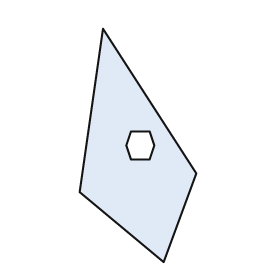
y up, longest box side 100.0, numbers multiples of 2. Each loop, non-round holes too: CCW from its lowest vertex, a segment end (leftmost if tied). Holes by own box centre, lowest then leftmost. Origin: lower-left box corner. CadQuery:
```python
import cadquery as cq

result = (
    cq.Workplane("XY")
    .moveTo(36.0, 0.0)
    .lineTo(50.0, 38.0)
    .lineTo(10.0, 100.0)
    .lineTo(0.0, 30.0)
    .close()
    .moveTo(22.0, 44.0)
    .lineTo(30.0, 44.0)
    .lineTo(32.0, 50.0)
    .lineTo(30.0, 56.0)
    .lineTo(22.0, 56.0)
    .lineTo(20.0, 50.0)
    .close()
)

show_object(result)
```